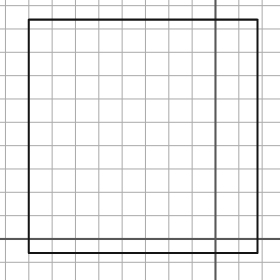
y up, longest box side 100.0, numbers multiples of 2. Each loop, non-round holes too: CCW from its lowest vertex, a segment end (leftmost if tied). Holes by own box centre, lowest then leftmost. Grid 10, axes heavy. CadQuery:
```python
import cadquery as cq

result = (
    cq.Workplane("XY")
    .moveTo(-80.0, -6.0)
    .lineTo(18.0, -6.0)
    .lineTo(18.0, 94.0)
    .lineTo(-80.0, 94.0)
    .close()
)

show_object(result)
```